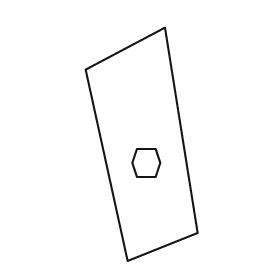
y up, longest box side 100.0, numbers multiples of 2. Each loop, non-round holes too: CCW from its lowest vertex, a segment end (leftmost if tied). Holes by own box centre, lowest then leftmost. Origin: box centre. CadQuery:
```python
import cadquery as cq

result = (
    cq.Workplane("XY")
    .moveTo(-6.0, -50.0)
    .lineTo(24.0, -38.0)
    .lineTo(10.0, 50.0)
    .lineTo(-24.0, 32.0)
    .close()
    .moveTo(-2.0, -14.0)
    .lineTo(6.0, -14.0)
    .lineTo(8.0, -8.0)
    .lineTo(6.0, -2.0)
    .lineTo(-2.0, -2.0)
    .lineTo(-4.0, -8.0)
    .close()
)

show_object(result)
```